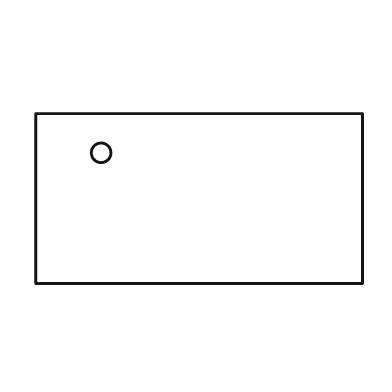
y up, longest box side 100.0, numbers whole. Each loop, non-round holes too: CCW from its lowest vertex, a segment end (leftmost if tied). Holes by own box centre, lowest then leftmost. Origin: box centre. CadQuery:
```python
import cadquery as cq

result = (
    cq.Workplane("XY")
    .moveTo(-50.0, -26.0)
    .lineTo(50.0, -26.0)
    .lineTo(50.0, 26.0)
    .lineTo(-50.0, 26.0)
    .close()
    .moveTo(-30.0, 14.0)
    .circle(3.0)
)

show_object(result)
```